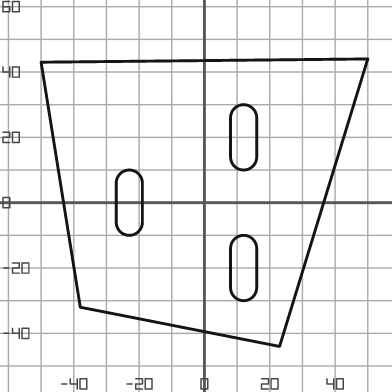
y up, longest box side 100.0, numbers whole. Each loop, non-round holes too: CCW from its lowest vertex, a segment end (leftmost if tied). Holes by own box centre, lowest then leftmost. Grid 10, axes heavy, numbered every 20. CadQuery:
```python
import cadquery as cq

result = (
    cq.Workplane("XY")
    .moveTo(23.0, -44.0)
    .lineTo(50.0, 44.0)
    .lineTo(-50.0, 43.0)
    .lineTo(-38.0, -32.0)
    .close()
    .moveTo(8.0, -26.0)
    .threePointArc((12.0, -30.0), (16.0, -26.0))
    .lineTo(16.0, -14.0)
    .threePointArc((12.0, -10.0), (8.0, -14.0))
    .close()
    .moveTo(-27.0, -6.0)
    .threePointArc((-23.0, -10.0), (-19.0, -6.0))
    .lineTo(-19.0, 6.0)
    .threePointArc((-23.0, 10.0), (-27.0, 6.0))
    .close()
    .moveTo(8.0, 14.0)
    .threePointArc((12.0, 10.0), (16.0, 14.0))
    .lineTo(16.0, 26.0)
    .threePointArc((12.0, 30.0), (8.0, 26.0))
    .close()
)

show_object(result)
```